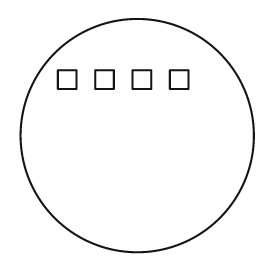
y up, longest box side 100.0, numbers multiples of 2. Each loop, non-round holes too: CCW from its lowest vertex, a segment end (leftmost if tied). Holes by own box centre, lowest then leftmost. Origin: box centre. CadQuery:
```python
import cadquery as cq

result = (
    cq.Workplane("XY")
    .moveTo(0.0, 0.0)
    .circle(50.0)
    .moveTo(-34.0, 20.0)
    .lineTo(-26.0, 20.0)
    .lineTo(-26.0, 28.0)
    .lineTo(-34.0, 28.0)
    .close()
    .moveTo(-18.0, 20.0)
    .lineTo(-10.0, 20.0)
    .lineTo(-10.0, 28.0)
    .lineTo(-18.0, 28.0)
    .close()
    .moveTo(-2.0, 20.0)
    .lineTo(6.0, 20.0)
    .lineTo(6.0, 28.0)
    .lineTo(-2.0, 28.0)
    .close()
    .moveTo(14.0, 20.0)
    .lineTo(22.0, 20.0)
    .lineTo(22.0, 28.0)
    .lineTo(14.0, 28.0)
    .close()
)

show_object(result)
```